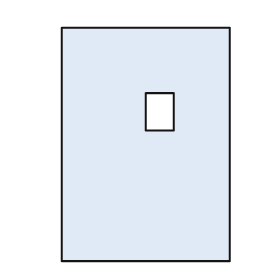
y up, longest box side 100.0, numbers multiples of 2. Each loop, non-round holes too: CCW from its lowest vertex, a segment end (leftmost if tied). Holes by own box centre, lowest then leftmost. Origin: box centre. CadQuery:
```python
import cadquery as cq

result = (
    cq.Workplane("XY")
    .moveTo(-36.0, -50.0)
    .lineTo(36.0, -50.0)
    .lineTo(36.0, 50.0)
    .lineTo(-36.0, 50.0)
    .close()
    .moveTo(0.0, 6.0)
    .lineTo(12.0, 6.0)
    .lineTo(12.0, 22.0)
    .lineTo(0.0, 22.0)
    .close()
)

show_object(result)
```